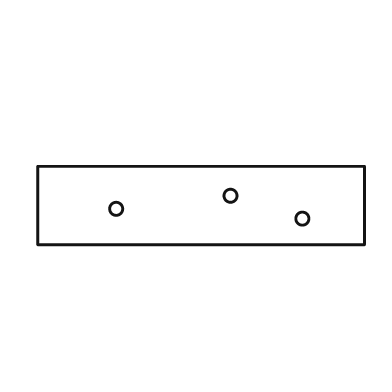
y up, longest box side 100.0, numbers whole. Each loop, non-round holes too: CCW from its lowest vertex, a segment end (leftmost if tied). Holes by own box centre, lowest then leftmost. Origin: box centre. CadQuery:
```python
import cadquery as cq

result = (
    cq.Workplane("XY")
    .moveTo(-50.0, -12.0)
    .lineTo(50.0, -12.0)
    .lineTo(50.0, 12.0)
    .lineTo(-50.0, 12.0)
    .close()
    .moveTo(31.0, -4.0)
    .circle(2.0)
    .moveTo(-26.0, -1.0)
    .circle(2.0)
    .moveTo(9.0, 3.0)
    .circle(2.0)
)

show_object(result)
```